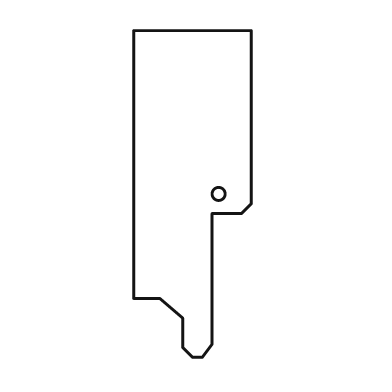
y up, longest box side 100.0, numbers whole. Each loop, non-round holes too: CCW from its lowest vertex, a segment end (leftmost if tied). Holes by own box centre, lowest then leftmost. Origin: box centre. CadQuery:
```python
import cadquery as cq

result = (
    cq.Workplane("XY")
    .moveTo(0.0, -50.0)
    .lineTo(3.0, -50.0)
    .lineTo(6.0, -46.0)
    .lineTo(6.0, -6.0)
    .lineTo(15.0, -6.0)
    .lineTo(18.0, -3.0)
    .lineTo(18.0, 50.0)
    .lineTo(-18.0, 50.0)
    .lineTo(-18.0, -32.0)
    .lineTo(-10.0, -32.0)
    .lineTo(-3.0, -38.0)
    .lineTo(-3.0, -47.0)
    .close()
    .moveTo(8.0, 0.0)
    .circle(2.0)
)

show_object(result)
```